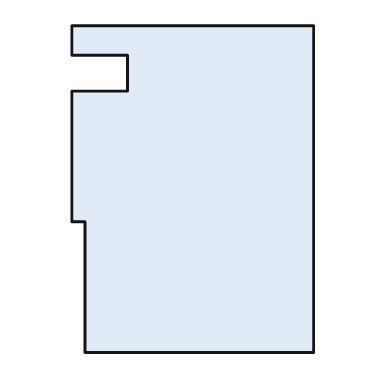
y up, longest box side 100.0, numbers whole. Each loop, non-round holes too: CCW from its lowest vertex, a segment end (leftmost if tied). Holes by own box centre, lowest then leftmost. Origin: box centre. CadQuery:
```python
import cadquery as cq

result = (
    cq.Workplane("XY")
    .moveTo(-33.0, -50.0)
    .lineTo(37.0, -50.0)
    .lineTo(37.0, 50.0)
    .lineTo(-37.0, 50.0)
    .lineTo(-37.0, 41.0)
    .lineTo(-20.0, 41.0)
    .lineTo(-20.0, 30.0)
    .lineTo(-37.0, 30.0)
    .lineTo(-37.0, -10.0)
    .lineTo(-33.0, -10.0)
    .close()
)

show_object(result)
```